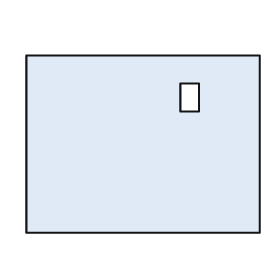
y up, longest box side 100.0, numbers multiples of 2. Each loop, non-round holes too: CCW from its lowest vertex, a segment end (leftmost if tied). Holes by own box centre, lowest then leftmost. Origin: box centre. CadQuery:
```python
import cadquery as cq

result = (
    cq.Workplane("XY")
    .moveTo(-50.0, -38.0)
    .lineTo(50.0, -38.0)
    .lineTo(50.0, 38.0)
    .lineTo(-50.0, 38.0)
    .close()
    .moveTo(16.0, 14.0)
    .lineTo(24.0, 14.0)
    .lineTo(24.0, 26.0)
    .lineTo(16.0, 26.0)
    .close()
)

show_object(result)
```